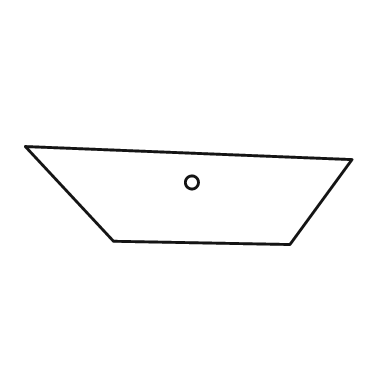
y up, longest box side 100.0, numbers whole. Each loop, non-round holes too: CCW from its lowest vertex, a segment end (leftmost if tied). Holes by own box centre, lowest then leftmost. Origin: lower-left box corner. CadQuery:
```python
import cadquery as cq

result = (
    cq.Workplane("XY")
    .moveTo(81.0, 0.0)
    .lineTo(100.0, 26.0)
    .lineTo(0.0, 30.0)
    .lineTo(27.0, 1.0)
    .close()
    .moveTo(51.0, 19.0)
    .circle(2.0)
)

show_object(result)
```